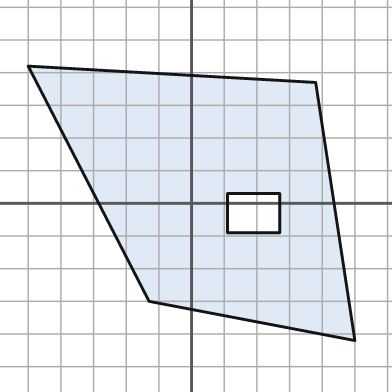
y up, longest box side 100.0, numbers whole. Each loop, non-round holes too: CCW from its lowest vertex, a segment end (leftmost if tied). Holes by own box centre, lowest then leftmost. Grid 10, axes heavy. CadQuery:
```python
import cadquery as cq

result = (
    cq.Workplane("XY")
    .moveTo(50.0, -42.0)
    .lineTo(38.0, 37.0)
    .lineTo(-50.0, 42.0)
    .lineTo(-13.0, -30.0)
    .close()
    .moveTo(11.0, -9.0)
    .lineTo(27.0, -9.0)
    .lineTo(27.0, 3.0)
    .lineTo(11.0, 3.0)
    .close()
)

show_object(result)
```